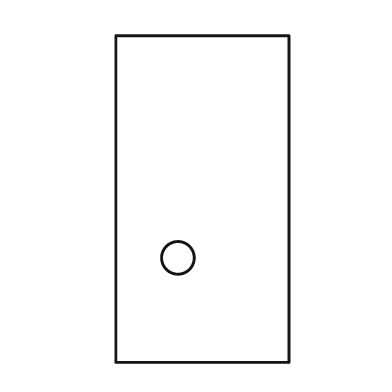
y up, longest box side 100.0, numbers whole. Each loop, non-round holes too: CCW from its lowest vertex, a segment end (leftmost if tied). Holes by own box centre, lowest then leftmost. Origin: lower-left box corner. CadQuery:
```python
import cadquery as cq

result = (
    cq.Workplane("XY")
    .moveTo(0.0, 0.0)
    .lineTo(53.0, 0.0)
    .lineTo(53.0, 100.0)
    .lineTo(0.0, 100.0)
    .close()
    .moveTo(19.0, 32.0)
    .circle(5.0)
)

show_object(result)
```